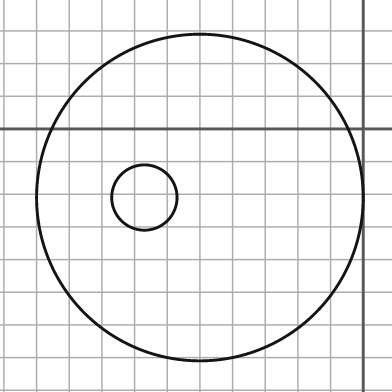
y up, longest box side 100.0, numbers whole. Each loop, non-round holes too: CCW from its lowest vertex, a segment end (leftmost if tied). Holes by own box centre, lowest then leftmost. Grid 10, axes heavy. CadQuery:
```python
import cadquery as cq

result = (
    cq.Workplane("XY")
    .moveTo(-50.0, -21.0)
    .circle(50.0)
    .moveTo(-67.0, -21.0)
    .circle(10.0)
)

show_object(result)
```